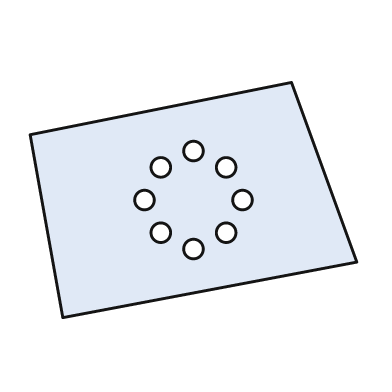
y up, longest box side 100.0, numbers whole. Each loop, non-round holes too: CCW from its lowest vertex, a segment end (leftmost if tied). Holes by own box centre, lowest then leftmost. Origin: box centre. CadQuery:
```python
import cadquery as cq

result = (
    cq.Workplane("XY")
    .moveTo(-40.0, -36.0)
    .lineTo(50.0, -19.0)
    .lineTo(30.0, 36.0)
    .lineTo(-50.0, 20.0)
    .close()
    .moveTo(0.0, -15.0)
    .circle(3.0)
    .moveTo(-10.0, -10.0)
    .circle(3.0)
    .moveTo(10.0, -10.0)
    .circle(3.0)
    .moveTo(-15.0, 0.0)
    .circle(3.0)
    .moveTo(15.0, 0.0)
    .circle(3.0)
    .moveTo(-10.0, 10.0)
    .circle(3.0)
    .moveTo(10.0, 10.0)
    .circle(3.0)
    .moveTo(0.0, 15.0)
    .circle(3.0)
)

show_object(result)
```